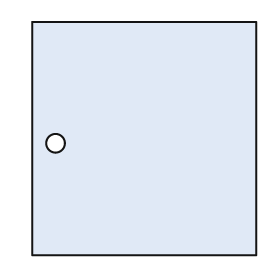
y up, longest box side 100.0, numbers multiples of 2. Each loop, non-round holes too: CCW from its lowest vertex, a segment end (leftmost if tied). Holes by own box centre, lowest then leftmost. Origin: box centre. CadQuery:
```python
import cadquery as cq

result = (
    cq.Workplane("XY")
    .moveTo(-48.0, -50.0)
    .lineTo(48.0, -50.0)
    .lineTo(48.0, 50.0)
    .lineTo(-48.0, 50.0)
    .close()
    .moveTo(-38.0, -2.0)
    .circle(4.0)
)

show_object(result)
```